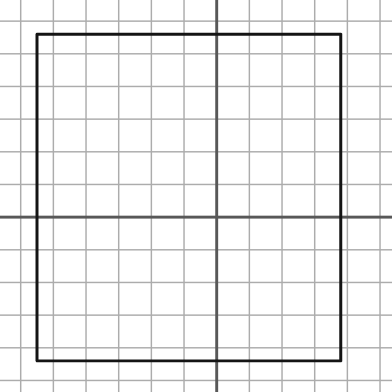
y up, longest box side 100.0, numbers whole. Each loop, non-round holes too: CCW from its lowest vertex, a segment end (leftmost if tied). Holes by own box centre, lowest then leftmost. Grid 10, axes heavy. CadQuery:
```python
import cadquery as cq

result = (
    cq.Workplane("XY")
    .moveTo(-55.0, -44.0)
    .lineTo(38.0, -44.0)
    .lineTo(38.0, 56.0)
    .lineTo(-55.0, 56.0)
    .close()
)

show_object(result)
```